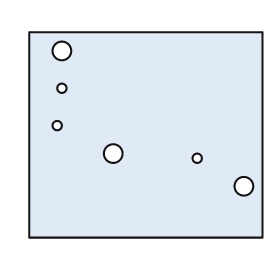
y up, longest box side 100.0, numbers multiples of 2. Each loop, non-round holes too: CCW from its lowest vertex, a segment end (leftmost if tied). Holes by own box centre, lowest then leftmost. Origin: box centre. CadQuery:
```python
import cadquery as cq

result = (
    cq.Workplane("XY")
    .moveTo(-50.0, -44.0)
    .lineTo(50.0, -44.0)
    .lineTo(50.0, 44.0)
    .lineTo(-50.0, 44.0)
    .close()
    .moveTo(42.0, -22.0)
    .circle(4.0)
    .moveTo(22.0, -10.0)
    .circle(2.0)
    .moveTo(-14.0, -8.0)
    .circle(4.0)
    .moveTo(-38.0, 4.0)
    .circle(2.0)
    .moveTo(-36.0, 20.0)
    .circle(2.0)
    .moveTo(-36.0, 36.0)
    .circle(4.0)
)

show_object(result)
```